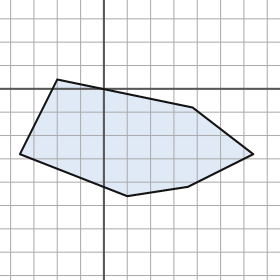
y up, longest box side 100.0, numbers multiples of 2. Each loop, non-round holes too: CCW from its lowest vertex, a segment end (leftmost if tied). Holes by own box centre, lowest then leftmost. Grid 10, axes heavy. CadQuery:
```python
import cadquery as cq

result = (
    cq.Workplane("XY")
    .moveTo(10.0, -46.0)
    .lineTo(36.0, -42.0)
    .lineTo(64.0, -28.0)
    .lineTo(38.0, -8.0)
    .lineTo(-20.0, 4.0)
    .lineTo(-36.0, -28.0)
    .close()
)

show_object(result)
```